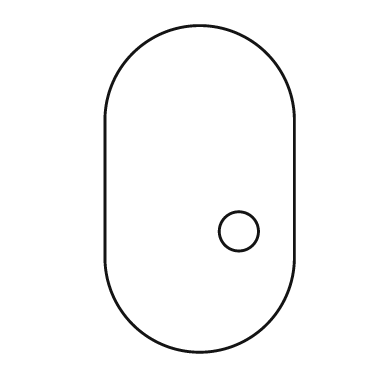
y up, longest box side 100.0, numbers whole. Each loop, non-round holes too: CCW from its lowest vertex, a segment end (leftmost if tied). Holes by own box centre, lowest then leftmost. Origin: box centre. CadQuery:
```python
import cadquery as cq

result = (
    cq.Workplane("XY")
    .moveTo(-29.0, -21.0)
    .threePointArc((0.0, -50.0), (29.0, -21.0))
    .lineTo(29.0, 21.0)
    .threePointArc((0.0, 50.0), (-29.0, 21.0))
    .close()
    .moveTo(12.0, -13.0)
    .circle(6.0)
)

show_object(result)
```